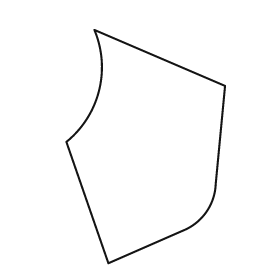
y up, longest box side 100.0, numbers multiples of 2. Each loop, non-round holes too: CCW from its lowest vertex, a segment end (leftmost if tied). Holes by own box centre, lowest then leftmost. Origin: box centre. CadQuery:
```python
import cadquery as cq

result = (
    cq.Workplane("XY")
    .moveTo(-16.0, -50.0)
    .lineTo(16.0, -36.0)
    .threePointArc((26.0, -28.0), (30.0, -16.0))
    .lineTo(34.0, 26.0)
    .lineTo(-22.0, 50.0)
    .threePointArc((-20.0, 24.0), (-34.0, 2.0))
    .close()
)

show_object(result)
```